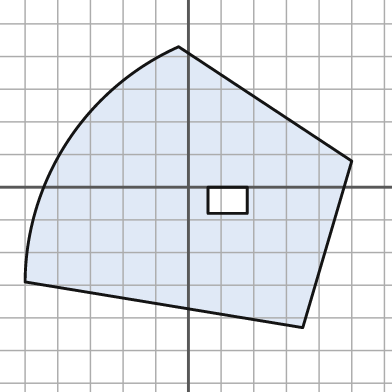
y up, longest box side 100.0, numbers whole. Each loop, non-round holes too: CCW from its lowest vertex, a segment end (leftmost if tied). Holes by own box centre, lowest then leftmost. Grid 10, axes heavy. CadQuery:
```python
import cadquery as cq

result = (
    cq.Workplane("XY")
    .moveTo(35.0, -43.0)
    .lineTo(50.0, 8.0)
    .lineTo(-3.0, 43.0)
    .threePointArc((-37.0, 14.0), (-50.0, -29.0))
    .close()
    .moveTo(6.0, -8.0)
    .lineTo(18.0, -8.0)
    .lineTo(18.0, 0.0)
    .lineTo(6.0, 0.0)
    .close()
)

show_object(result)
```